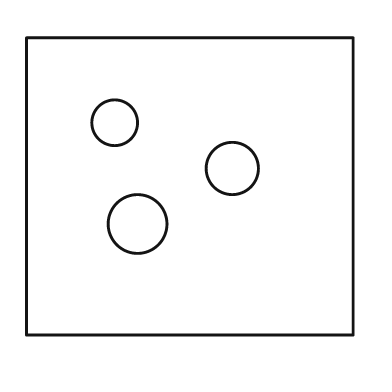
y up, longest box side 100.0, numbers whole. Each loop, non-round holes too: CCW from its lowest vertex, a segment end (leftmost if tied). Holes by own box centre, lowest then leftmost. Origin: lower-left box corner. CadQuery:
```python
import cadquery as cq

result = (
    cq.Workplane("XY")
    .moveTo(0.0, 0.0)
    .lineTo(100.0, 0.0)
    .lineTo(100.0, 91.0)
    .lineTo(0.0, 91.0)
    .close()
    .moveTo(34.0, 34.0)
    .circle(9.0)
    .moveTo(63.0, 51.0)
    .circle(8.0)
    .moveTo(27.0, 65.0)
    .circle(7.0)
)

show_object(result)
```